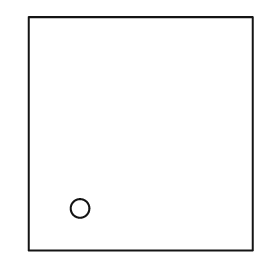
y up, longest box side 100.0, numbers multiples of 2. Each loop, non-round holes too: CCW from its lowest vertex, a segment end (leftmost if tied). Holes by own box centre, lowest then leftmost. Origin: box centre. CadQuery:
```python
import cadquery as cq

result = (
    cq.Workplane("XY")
    .moveTo(-48.0, -50.0)
    .lineTo(48.0, -50.0)
    .lineTo(48.0, 50.0)
    .lineTo(-48.0, 50.0)
    .close()
    .moveTo(-26.0, -32.0)
    .circle(4.0)
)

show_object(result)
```